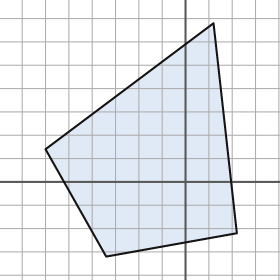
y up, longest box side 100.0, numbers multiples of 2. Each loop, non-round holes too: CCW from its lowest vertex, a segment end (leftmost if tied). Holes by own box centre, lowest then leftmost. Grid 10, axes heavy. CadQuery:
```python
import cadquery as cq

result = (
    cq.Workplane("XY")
    .moveTo(-34.0, -32.0)
    .lineTo(22.0, -22.0)
    .lineTo(12.0, 68.0)
    .lineTo(-60.0, 14.0)
    .close()
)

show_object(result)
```